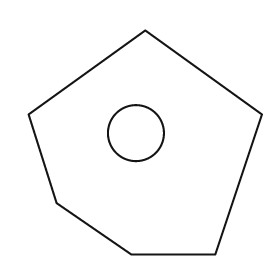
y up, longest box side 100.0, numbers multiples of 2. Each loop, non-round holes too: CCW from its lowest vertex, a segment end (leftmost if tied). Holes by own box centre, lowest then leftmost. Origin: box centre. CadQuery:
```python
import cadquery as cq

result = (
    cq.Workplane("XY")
    .moveTo(-6.0, -48.0)
    .lineTo(30.0, -48.0)
    .lineTo(50.0, 12.0)
    .lineTo(0.0, 48.0)
    .lineTo(-50.0, 12.0)
    .lineTo(-38.0, -26.0)
    .close()
    .moveTo(-4.0, 4.0)
    .circle(12.0)
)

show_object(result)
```